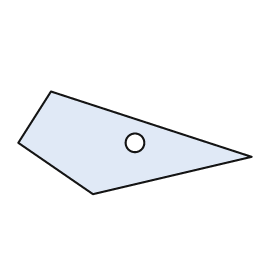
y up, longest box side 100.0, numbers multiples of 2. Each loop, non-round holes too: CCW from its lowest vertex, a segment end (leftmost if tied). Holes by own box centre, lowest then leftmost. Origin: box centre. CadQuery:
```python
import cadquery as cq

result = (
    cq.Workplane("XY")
    .moveTo(-18.0, -22.0)
    .lineTo(50.0, -6.0)
    .lineTo(-36.0, 22.0)
    .lineTo(-50.0, 0.0)
    .close()
    .moveTo(0.0, 0.0)
    .circle(4.0)
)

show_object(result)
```